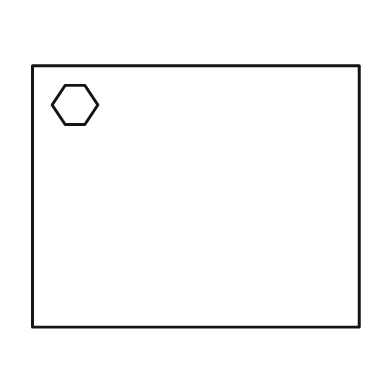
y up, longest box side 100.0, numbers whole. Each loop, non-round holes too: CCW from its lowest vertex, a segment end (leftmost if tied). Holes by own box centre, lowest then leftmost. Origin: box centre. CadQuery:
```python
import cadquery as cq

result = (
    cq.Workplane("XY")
    .moveTo(-50.0, -40.0)
    .lineTo(50.0, -40.0)
    .lineTo(50.0, 40.0)
    .lineTo(-50.0, 40.0)
    .close()
    .moveTo(-40.0, 22.0)
    .lineTo(-34.0, 22.0)
    .lineTo(-30.0, 28.0)
    .lineTo(-34.0, 34.0)
    .lineTo(-40.0, 34.0)
    .lineTo(-44.0, 28.0)
    .close()
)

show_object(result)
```